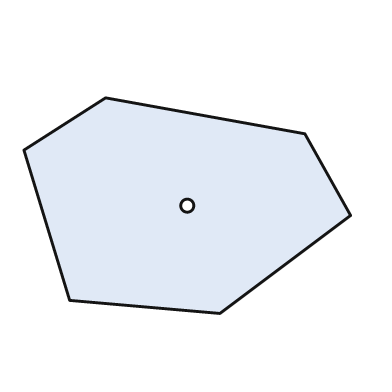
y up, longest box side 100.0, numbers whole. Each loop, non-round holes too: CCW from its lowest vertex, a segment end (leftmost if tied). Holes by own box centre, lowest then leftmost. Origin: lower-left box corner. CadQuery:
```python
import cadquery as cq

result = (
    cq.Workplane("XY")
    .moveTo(60.0, 0.0)
    .lineTo(100.0, 30.0)
    .lineTo(86.0, 55.0)
    .lineTo(25.0, 66.0)
    .lineTo(0.0, 50.0)
    .lineTo(14.0, 4.0)
    .close()
    .moveTo(50.0, 33.0)
    .circle(2.0)
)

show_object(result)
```